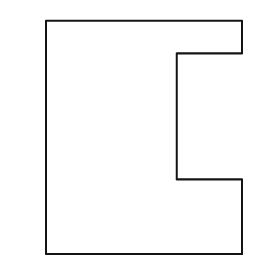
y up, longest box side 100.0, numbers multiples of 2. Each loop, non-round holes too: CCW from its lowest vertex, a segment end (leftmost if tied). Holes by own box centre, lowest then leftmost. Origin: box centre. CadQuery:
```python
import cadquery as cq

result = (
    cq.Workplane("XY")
    .moveTo(-42.0, -50.0)
    .lineTo(42.0, -50.0)
    .lineTo(42.0, -18.0)
    .lineTo(14.0, -18.0)
    .lineTo(14.0, 36.0)
    .lineTo(42.0, 36.0)
    .lineTo(42.0, 50.0)
    .lineTo(-42.0, 50.0)
    .close()
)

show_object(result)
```